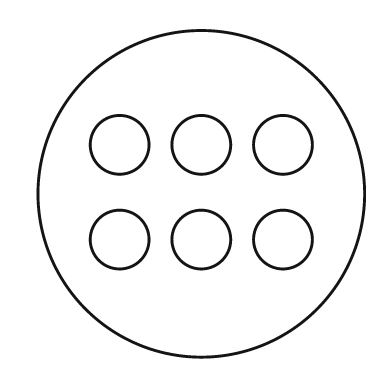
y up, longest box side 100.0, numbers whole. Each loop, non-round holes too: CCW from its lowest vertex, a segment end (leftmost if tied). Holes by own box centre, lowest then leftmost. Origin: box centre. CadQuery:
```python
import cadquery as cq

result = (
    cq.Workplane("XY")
    .moveTo(0.0, 0.0)
    .circle(50.0)
    .moveTo(-25.0, -14.0)
    .circle(9.0)
    .moveTo(0.0, -14.0)
    .circle(9.0)
    .moveTo(25.0, -14.0)
    .circle(9.0)
    .moveTo(-25.0, 15.0)
    .circle(9.0)
    .moveTo(0.0, 15.0)
    .circle(9.0)
    .moveTo(25.0, 15.0)
    .circle(9.0)
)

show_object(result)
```